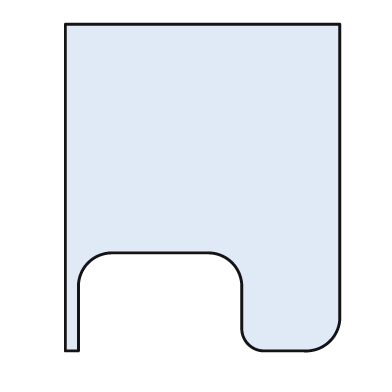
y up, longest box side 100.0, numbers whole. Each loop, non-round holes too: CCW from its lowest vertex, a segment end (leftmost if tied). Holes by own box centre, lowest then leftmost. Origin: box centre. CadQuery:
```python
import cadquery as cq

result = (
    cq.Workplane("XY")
    .moveTo(-42.0, -50.0)
    .lineTo(-38.0, -50.0)
    .lineTo(-38.0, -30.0)
    .threePointArc((-35.0, -23.0), (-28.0, -20.0))
    .lineTo(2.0, -20.0)
    .threePointArc((9.0, -23.0), (12.0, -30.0))
    .lineTo(12.0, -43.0)
    .threePointArc((14.0, -48.0), (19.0, -50.0))
    .lineTo(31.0, -50.0)
    .threePointArc((39.0, -47.0), (42.0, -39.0))
    .lineTo(42.0, 50.0)
    .lineTo(-42.0, 50.0)
    .close()
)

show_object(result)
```